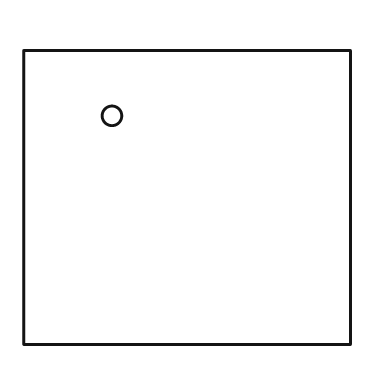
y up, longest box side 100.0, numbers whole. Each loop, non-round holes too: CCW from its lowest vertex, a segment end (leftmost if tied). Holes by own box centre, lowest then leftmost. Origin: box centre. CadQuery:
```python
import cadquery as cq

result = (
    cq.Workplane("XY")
    .moveTo(-50.0, -45.0)
    .lineTo(50.0, -45.0)
    .lineTo(50.0, 45.0)
    .lineTo(-50.0, 45.0)
    .close()
    .moveTo(-23.0, 25.0)
    .circle(3.0)
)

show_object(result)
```